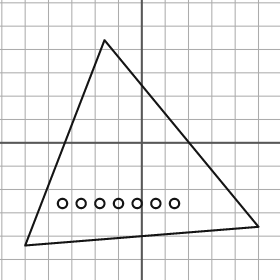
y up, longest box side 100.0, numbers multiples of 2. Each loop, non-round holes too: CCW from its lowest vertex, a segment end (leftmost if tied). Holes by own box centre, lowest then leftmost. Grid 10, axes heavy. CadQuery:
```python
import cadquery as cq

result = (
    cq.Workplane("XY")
    .moveTo(-50.0, -44.0)
    .lineTo(50.0, -36.0)
    .lineTo(-16.0, 44.0)
    .close()
    .moveTo(-34.0, -26.0)
    .circle(2.0)
    .moveTo(-26.0, -26.0)
    .circle(2.0)
    .moveTo(-18.0, -26.0)
    .circle(2.0)
    .moveTo(-10.0, -26.0)
    .circle(2.0)
    .moveTo(-2.0, -26.0)
    .circle(2.0)
    .moveTo(6.0, -26.0)
    .circle(2.0)
    .moveTo(14.0, -26.0)
    .circle(2.0)
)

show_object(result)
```